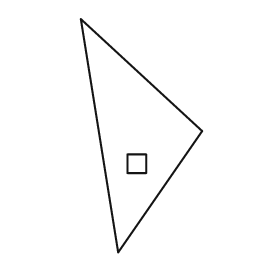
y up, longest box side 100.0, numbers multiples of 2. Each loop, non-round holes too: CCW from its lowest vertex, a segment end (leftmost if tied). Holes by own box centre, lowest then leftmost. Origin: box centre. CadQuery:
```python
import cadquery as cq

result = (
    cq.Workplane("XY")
    .moveTo(-10.0, -50.0)
    .lineTo(26.0, 2.0)
    .lineTo(-26.0, 50.0)
    .close()
    .moveTo(-6.0, -16.0)
    .lineTo(2.0, -16.0)
    .lineTo(2.0, -8.0)
    .lineTo(-6.0, -8.0)
    .close()
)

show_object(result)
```